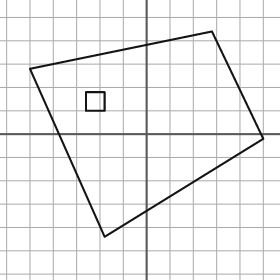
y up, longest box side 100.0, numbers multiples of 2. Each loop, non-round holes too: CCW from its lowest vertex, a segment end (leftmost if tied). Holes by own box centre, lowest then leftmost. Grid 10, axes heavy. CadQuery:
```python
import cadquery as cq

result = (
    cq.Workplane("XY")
    .moveTo(-18.0, -44.0)
    .lineTo(50.0, -2.0)
    .lineTo(28.0, 44.0)
    .lineTo(-50.0, 28.0)
    .close()
    .moveTo(-26.0, 10.0)
    .lineTo(-18.0, 10.0)
    .lineTo(-18.0, 18.0)
    .lineTo(-26.0, 18.0)
    .close()
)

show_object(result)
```